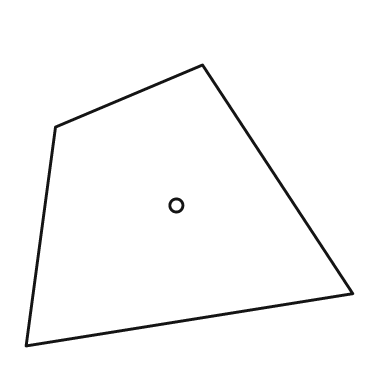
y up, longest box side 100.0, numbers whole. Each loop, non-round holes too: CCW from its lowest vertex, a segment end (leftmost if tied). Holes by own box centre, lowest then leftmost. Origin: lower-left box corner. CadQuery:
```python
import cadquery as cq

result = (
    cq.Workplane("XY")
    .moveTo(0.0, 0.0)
    .lineTo(100.0, 16.0)
    .lineTo(54.0, 86.0)
    .lineTo(9.0, 67.0)
    .close()
    .moveTo(46.0, 43.0)
    .circle(2.0)
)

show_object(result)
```